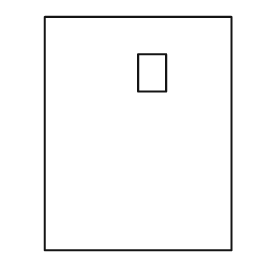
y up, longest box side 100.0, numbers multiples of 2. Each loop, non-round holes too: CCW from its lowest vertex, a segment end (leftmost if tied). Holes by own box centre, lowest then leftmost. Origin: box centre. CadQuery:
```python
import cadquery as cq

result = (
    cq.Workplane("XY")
    .moveTo(-40.0, -50.0)
    .lineTo(40.0, -50.0)
    .lineTo(40.0, 50.0)
    .lineTo(-40.0, 50.0)
    .close()
    .moveTo(0.0, 18.0)
    .lineTo(12.0, 18.0)
    .lineTo(12.0, 34.0)
    .lineTo(0.0, 34.0)
    .close()
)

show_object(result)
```